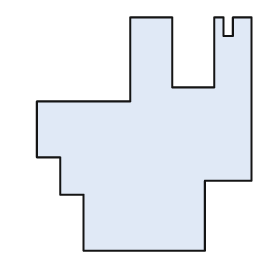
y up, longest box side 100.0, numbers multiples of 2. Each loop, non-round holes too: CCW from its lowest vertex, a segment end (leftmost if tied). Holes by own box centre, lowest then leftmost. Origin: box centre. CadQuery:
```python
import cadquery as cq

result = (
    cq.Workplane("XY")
    .moveTo(-26.0, -50.0)
    .lineTo(26.0, -50.0)
    .lineTo(26.0, -20.0)
    .lineTo(46.0, -20.0)
    .lineTo(46.0, 50.0)
    .lineTo(38.0, 50.0)
    .lineTo(38.0, 42.0)
    .lineTo(34.0, 42.0)
    .lineTo(34.0, 50.0)
    .lineTo(30.0, 50.0)
    .lineTo(30.0, 20.0)
    .lineTo(12.0, 20.0)
    .lineTo(12.0, 50.0)
    .lineTo(-6.0, 50.0)
    .lineTo(-6.0, 14.0)
    .lineTo(-46.0, 14.0)
    .lineTo(-46.0, -10.0)
    .lineTo(-36.0, -10.0)
    .lineTo(-36.0, -26.0)
    .lineTo(-26.0, -26.0)
    .close()
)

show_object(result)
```